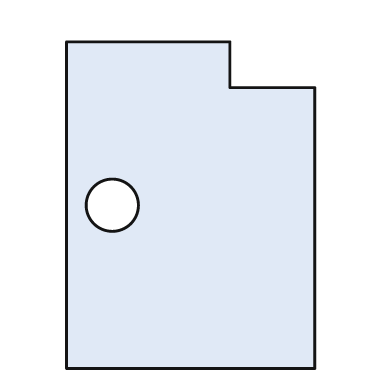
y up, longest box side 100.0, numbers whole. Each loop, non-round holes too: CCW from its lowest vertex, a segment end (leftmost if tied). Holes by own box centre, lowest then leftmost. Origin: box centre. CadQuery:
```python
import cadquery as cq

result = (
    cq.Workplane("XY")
    .moveTo(-38.0, -50.0)
    .lineTo(38.0, -50.0)
    .lineTo(38.0, 36.0)
    .lineTo(12.0, 36.0)
    .lineTo(12.0, 50.0)
    .lineTo(-38.0, 50.0)
    .close()
    .moveTo(-24.0, 0.0)
    .circle(8.0)
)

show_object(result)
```